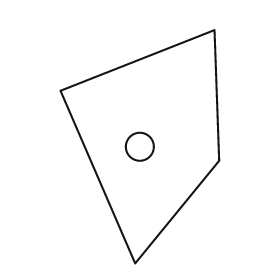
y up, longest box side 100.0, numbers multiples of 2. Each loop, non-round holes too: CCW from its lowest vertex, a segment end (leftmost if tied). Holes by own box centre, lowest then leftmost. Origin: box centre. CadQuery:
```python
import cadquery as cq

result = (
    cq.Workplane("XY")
    .moveTo(-2.0, -50.0)
    .lineTo(34.0, -6.0)
    .lineTo(32.0, 50.0)
    .lineTo(-34.0, 24.0)
    .close()
    .moveTo(0.0, 0.0)
    .circle(6.0)
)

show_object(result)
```